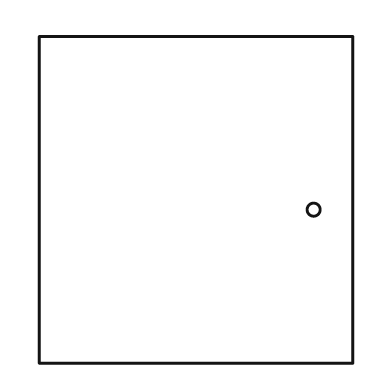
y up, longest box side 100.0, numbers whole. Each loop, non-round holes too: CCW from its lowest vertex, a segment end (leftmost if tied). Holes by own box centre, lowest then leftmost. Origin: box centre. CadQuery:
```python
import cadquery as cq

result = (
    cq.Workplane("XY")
    .moveTo(-48.0, -50.0)
    .lineTo(48.0, -50.0)
    .lineTo(48.0, 50.0)
    .lineTo(-48.0, 50.0)
    .close()
    .moveTo(36.0, -3.0)
    .circle(2.0)
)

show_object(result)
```